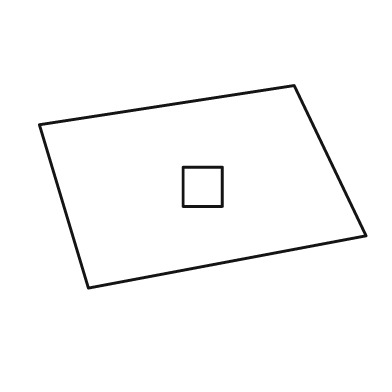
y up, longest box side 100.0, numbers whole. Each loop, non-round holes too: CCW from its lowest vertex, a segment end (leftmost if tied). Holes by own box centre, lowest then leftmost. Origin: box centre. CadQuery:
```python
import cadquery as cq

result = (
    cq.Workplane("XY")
    .moveTo(-35.0, -31.0)
    .lineTo(50.0, -15.0)
    .lineTo(28.0, 31.0)
    .lineTo(-50.0, 19.0)
    .close()
    .moveTo(-6.0, -6.0)
    .lineTo(6.0, -6.0)
    .lineTo(6.0, 6.0)
    .lineTo(-6.0, 6.0)
    .close()
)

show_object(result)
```